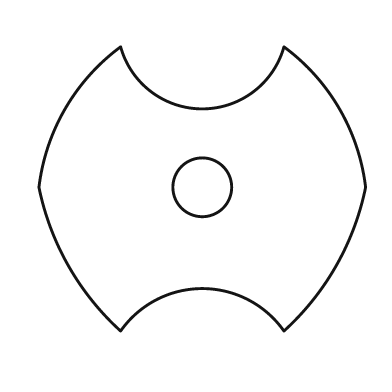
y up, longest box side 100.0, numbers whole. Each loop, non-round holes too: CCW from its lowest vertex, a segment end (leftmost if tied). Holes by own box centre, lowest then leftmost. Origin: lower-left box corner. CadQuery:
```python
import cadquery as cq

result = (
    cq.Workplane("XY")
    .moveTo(25.0, 0.0)
    .threePointArc((50.0, 13.0), (75.0, 0.0))
    .threePointArc((91.0, 20.0), (100.0, 44.0))
    .threePointArc((92.0, 68.0), (75.0, 87.0))
    .threePointArc((50.0, 68.0), (25.0, 87.0))
    .threePointArc((8.0, 68.0), (0.0, 44.0))
    .threePointArc((9.0, 20.0), (25.0, 0.0))
    .close()
    .moveTo(50.0, 44.0)
    .circle(9.0)
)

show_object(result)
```